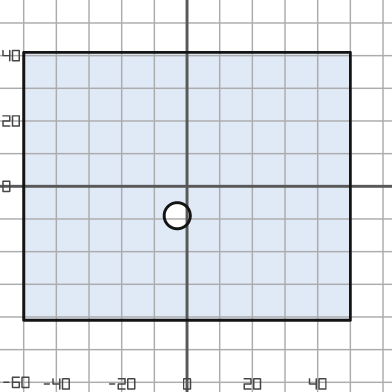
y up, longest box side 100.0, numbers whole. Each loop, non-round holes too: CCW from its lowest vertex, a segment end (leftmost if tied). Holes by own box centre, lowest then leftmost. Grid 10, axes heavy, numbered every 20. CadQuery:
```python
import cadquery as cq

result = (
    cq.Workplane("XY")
    .moveTo(-50.0, -41.0)
    .lineTo(50.0, -41.0)
    .lineTo(50.0, 41.0)
    .lineTo(-50.0, 41.0)
    .close()
    .moveTo(-3.0, -9.0)
    .circle(4.0)
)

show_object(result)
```